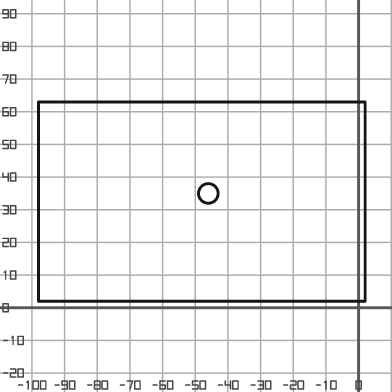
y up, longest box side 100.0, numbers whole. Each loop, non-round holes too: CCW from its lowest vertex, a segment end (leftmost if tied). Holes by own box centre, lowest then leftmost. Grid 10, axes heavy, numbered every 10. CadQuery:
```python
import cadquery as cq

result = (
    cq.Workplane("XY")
    .moveTo(-98.0, 2.0)
    .lineTo(2.0, 2.0)
    .lineTo(2.0, 63.0)
    .lineTo(-98.0, 63.0)
    .close()
    .moveTo(-46.0, 35.0)
    .circle(3.0)
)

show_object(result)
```